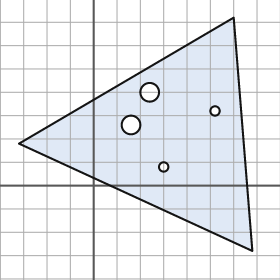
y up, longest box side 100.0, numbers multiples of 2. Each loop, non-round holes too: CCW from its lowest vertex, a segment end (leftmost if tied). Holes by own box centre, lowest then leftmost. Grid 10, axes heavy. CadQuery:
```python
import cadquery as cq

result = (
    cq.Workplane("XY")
    .moveTo(68.0, -28.0)
    .lineTo(60.0, 72.0)
    .lineTo(-32.0, 18.0)
    .close()
    .moveTo(30.0, 8.0)
    .circle(2.0)
    .moveTo(16.0, 26.0)
    .circle(4.0)
    .moveTo(52.0, 32.0)
    .circle(2.0)
    .moveTo(24.0, 40.0)
    .circle(4.0)
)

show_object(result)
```